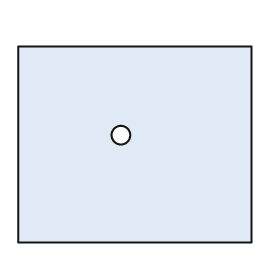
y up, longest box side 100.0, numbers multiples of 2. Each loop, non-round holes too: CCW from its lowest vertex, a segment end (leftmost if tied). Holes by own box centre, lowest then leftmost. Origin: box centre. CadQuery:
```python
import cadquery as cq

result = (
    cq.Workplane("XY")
    .moveTo(-50.0, -42.0)
    .lineTo(50.0, -42.0)
    .lineTo(50.0, 42.0)
    .lineTo(-50.0, 42.0)
    .close()
    .moveTo(-6.0, 4.0)
    .circle(4.0)
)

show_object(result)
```